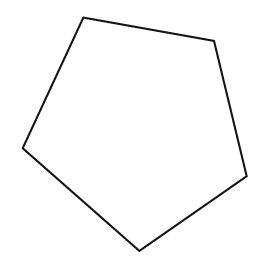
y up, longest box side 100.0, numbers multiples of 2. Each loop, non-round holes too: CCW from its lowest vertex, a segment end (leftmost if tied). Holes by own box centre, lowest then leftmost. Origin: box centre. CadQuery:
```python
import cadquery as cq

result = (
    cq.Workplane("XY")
    .moveTo(2.0, -50.0)
    .lineTo(48.0, -18.0)
    .lineTo(34.0, 40.0)
    .lineTo(-22.0, 50.0)
    .lineTo(-48.0, -6.0)
    .close()
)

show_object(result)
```